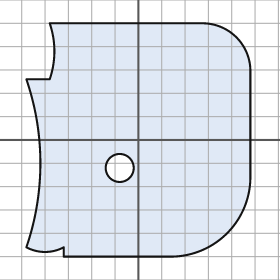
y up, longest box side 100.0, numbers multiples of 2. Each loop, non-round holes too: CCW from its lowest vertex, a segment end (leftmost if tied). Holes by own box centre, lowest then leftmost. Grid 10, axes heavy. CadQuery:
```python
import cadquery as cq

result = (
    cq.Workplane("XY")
    .moveTo(-32.0, -50.0)
    .lineTo(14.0, -50.0)
    .threePointArc((38.0, -40.0), (48.0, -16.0))
    .lineTo(48.0, 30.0)
    .threePointArc((42.0, 44.0), (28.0, 50.0))
    .lineTo(-38.0, 50.0)
    .threePointArc((-36.0, 38.0), (-38.0, 26.0))
    .lineTo(-48.0, 26.0)
    .threePointArc((-42.0, -10.0), (-48.0, -46.0))
    .threePointArc((-40.0, -48.0), (-32.0, -46.0))
    .close()
    .moveTo(-8.0, -12.0)
    .circle(6.0)
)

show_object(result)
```